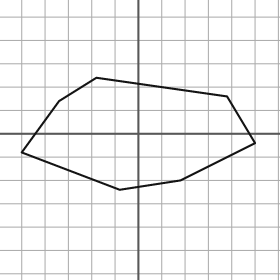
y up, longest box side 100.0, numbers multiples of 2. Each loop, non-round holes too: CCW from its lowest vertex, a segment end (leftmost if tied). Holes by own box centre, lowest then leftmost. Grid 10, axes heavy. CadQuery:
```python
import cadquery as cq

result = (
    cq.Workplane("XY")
    .moveTo(-8.0, -24.0)
    .lineTo(18.0, -20.0)
    .lineTo(50.0, -4.0)
    .lineTo(38.0, 16.0)
    .lineTo(-18.0, 24.0)
    .lineTo(-34.0, 14.0)
    .lineTo(-50.0, -8.0)
    .close()
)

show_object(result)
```